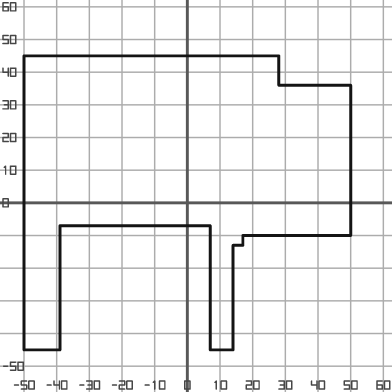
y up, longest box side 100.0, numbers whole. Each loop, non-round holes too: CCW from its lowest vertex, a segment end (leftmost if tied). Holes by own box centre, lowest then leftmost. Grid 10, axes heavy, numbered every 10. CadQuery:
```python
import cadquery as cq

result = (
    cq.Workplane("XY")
    .moveTo(-50.0, -45.0)
    .lineTo(-39.0, -45.0)
    .lineTo(-39.0, -7.0)
    .lineTo(7.0, -7.0)
    .lineTo(7.0, -45.0)
    .lineTo(14.0, -45.0)
    .lineTo(14.0, -13.0)
    .lineTo(17.0, -13.0)
    .lineTo(17.0, -10.0)
    .lineTo(50.0, -10.0)
    .lineTo(50.0, 36.0)
    .lineTo(28.0, 36.0)
    .lineTo(28.0, 45.0)
    .lineTo(-50.0, 45.0)
    .close()
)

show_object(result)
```